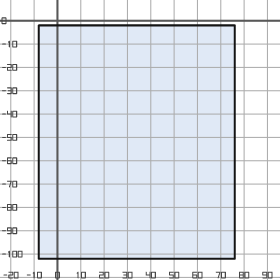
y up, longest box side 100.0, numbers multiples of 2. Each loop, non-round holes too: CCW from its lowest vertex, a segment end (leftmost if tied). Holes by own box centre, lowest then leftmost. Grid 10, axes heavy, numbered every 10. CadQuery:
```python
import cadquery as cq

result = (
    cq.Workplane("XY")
    .moveTo(-8.0, -102.0)
    .lineTo(76.0, -102.0)
    .lineTo(76.0, -2.0)
    .lineTo(-8.0, -2.0)
    .close()
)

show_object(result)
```